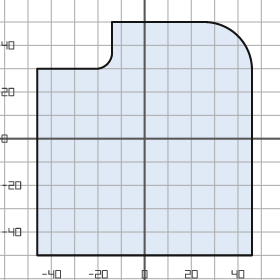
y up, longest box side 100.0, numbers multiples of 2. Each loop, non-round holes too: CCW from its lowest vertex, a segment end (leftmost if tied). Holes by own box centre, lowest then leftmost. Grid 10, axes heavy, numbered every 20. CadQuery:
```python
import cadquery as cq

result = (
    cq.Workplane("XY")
    .moveTo(-46.0, -50.0)
    .lineTo(46.0, -50.0)
    .lineTo(46.0, 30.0)
    .threePointArc((40.0, 44.0), (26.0, 50.0))
    .lineTo(-14.0, 50.0)
    .lineTo(-14.0, 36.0)
    .threePointArc((-16.0, 32.0), (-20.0, 30.0))
    .lineTo(-46.0, 30.0)
    .close()
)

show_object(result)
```